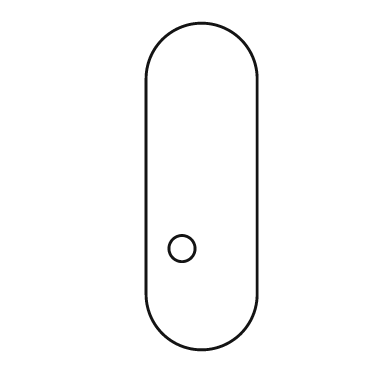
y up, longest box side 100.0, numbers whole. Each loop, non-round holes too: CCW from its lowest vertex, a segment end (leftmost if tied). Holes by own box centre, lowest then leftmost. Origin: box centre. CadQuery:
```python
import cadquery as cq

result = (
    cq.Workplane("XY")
    .moveTo(-17.0, -33.0)
    .threePointArc((0.0, -50.0), (17.0, -33.0))
    .lineTo(17.0, 33.0)
    .threePointArc((0.0, 50.0), (-17.0, 33.0))
    .close()
    .moveTo(-6.0, -19.0)
    .circle(4.0)
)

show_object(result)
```